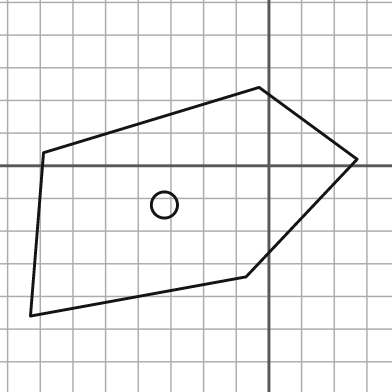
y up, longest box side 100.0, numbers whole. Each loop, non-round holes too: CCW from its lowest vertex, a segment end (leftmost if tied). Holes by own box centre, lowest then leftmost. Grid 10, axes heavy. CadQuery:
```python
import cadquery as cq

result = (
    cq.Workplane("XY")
    .moveTo(-73.0, -46.0)
    .lineTo(-7.0, -34.0)
    .lineTo(27.0, 2.0)
    .lineTo(-3.0, 24.0)
    .lineTo(-69.0, 4.0)
    .close()
    .moveTo(-32.0, -12.0)
    .circle(4.0)
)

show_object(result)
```